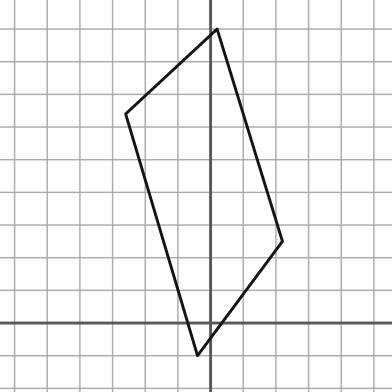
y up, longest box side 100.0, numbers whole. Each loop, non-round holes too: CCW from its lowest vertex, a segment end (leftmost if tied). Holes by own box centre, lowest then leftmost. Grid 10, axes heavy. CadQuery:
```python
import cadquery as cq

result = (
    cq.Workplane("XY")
    .moveTo(-4.0, -10.0)
    .lineTo(22.0, 25.0)
    .lineTo(2.0, 90.0)
    .lineTo(-26.0, 64.0)
    .close()
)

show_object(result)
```